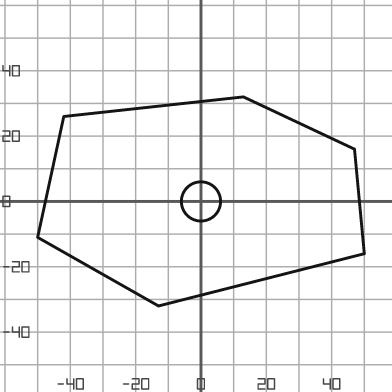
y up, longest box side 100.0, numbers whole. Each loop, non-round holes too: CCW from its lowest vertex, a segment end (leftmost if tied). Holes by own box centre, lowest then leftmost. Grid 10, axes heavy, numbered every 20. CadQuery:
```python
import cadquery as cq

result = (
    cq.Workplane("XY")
    .moveTo(-13.0, -32.0)
    .lineTo(50.0, -16.0)
    .lineTo(47.0, 16.0)
    .lineTo(13.0, 32.0)
    .lineTo(-42.0, 26.0)
    .lineTo(-50.0, -11.0)
    .close()
    .moveTo(0.0, 0.0)
    .circle(6.0)
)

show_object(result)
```